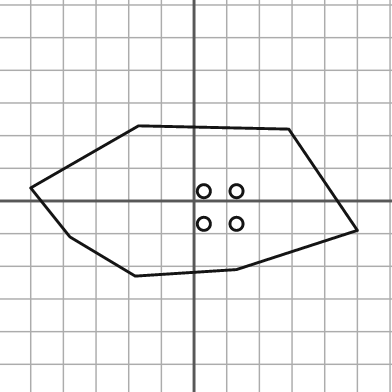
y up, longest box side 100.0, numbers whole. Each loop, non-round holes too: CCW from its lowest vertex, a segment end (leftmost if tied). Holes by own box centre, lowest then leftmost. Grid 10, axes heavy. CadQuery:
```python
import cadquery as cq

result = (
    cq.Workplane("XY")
    .moveTo(-18.0, -23.0)
    .lineTo(13.0, -21.0)
    .lineTo(50.0, -9.0)
    .lineTo(29.0, 22.0)
    .lineTo(-17.0, 23.0)
    .lineTo(-50.0, 4.0)
    .lineTo(-38.0, -11.0)
    .close()
    .moveTo(3.0, -7.0)
    .circle(2.0)
    .moveTo(13.0, -7.0)
    .circle(2.0)
    .moveTo(3.0, 3.0)
    .circle(2.0)
    .moveTo(13.0, 3.0)
    .circle(2.0)
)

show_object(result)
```